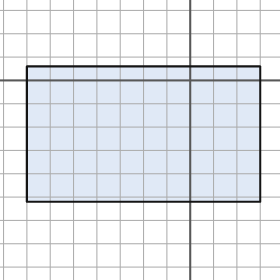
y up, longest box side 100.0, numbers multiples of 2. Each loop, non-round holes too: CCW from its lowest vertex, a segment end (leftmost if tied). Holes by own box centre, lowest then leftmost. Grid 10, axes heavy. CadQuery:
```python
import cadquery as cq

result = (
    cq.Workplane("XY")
    .moveTo(-70.0, -52.0)
    .lineTo(30.0, -52.0)
    .lineTo(30.0, 6.0)
    .lineTo(-70.0, 6.0)
    .close()
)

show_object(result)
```